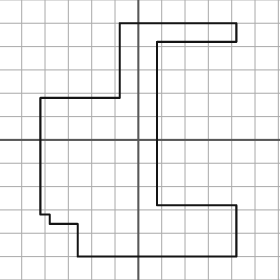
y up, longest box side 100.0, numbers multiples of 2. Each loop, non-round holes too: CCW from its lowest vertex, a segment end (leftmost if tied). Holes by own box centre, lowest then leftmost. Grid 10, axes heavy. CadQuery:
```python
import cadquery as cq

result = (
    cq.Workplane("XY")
    .moveTo(-26.0, -50.0)
    .lineTo(42.0, -50.0)
    .lineTo(42.0, -28.0)
    .lineTo(8.0, -28.0)
    .lineTo(8.0, 42.0)
    .lineTo(42.0, 42.0)
    .lineTo(42.0, 50.0)
    .lineTo(-8.0, 50.0)
    .lineTo(-8.0, 18.0)
    .lineTo(-42.0, 18.0)
    .lineTo(-42.0, -32.0)
    .lineTo(-38.0, -32.0)
    .lineTo(-38.0, -36.0)
    .lineTo(-26.0, -36.0)
    .close()
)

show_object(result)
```